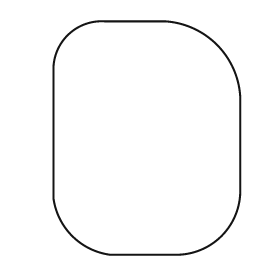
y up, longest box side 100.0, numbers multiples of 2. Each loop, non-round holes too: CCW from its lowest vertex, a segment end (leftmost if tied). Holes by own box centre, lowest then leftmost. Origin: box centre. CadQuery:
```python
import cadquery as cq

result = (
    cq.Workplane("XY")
    .moveTo(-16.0, -50.0)
    .lineTo(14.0, -50.0)
    .threePointArc((32.0, -42.0), (40.0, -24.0))
    .lineTo(40.0, 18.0)
    .threePointArc((30.0, 40.0), (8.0, 50.0))
    .lineTo(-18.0, 50.0)
    .threePointArc((-34.0, 44.0), (-40.0, 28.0))
    .lineTo(-40.0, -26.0)
    .threePointArc((-32.0, -42.0), (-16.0, -50.0))
    .close()
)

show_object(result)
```